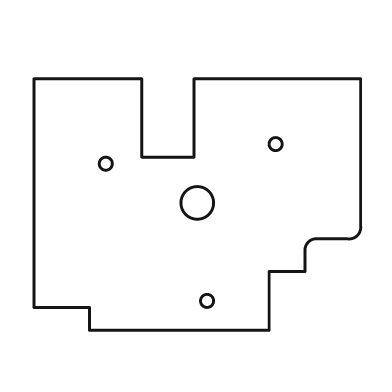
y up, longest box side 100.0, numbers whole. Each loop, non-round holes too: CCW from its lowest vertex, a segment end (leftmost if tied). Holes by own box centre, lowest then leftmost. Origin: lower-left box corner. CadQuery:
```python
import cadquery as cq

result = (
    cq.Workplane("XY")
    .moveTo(17.0, 0.0)
    .lineTo(72.0, 0.0)
    .lineTo(72.0, 18.0)
    .lineTo(83.0, 18.0)
    .lineTo(83.0, 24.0)
    .threePointArc((84.0, 27.0), (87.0, 28.0))
    .lineTo(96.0, 28.0)
    .threePointArc((99.0, 29.0), (100.0, 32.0))
    .lineTo(100.0, 77.0)
    .lineTo(49.0, 77.0)
    .lineTo(49.0, 53.0)
    .lineTo(33.0, 53.0)
    .lineTo(33.0, 77.0)
    .lineTo(0.0, 77.0)
    .lineTo(0.0, 7.0)
    .lineTo(17.0, 7.0)
    .close()
    .moveTo(53.0, 9.0)
    .circle(2.0)
    .moveTo(50.0, 39.0)
    .circle(5.0)
    .moveTo(22.0, 51.0)
    .circle(2.0)
    .moveTo(74.0, 57.0)
    .circle(2.0)
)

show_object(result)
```